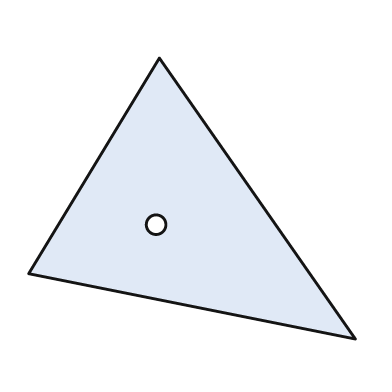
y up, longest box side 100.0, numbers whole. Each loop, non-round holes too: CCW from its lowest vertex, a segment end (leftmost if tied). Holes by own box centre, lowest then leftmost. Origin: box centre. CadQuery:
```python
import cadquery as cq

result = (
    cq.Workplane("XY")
    .moveTo(50.0, -43.0)
    .lineTo(-10.0, 43.0)
    .lineTo(-50.0, -23.0)
    .close()
    .moveTo(-11.0, -8.0)
    .circle(3.0)
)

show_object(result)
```